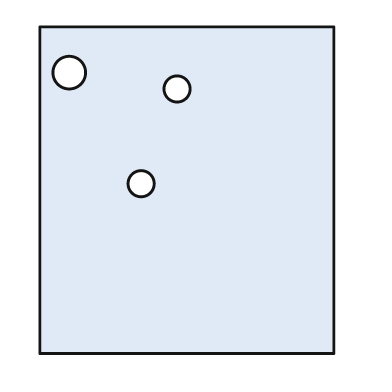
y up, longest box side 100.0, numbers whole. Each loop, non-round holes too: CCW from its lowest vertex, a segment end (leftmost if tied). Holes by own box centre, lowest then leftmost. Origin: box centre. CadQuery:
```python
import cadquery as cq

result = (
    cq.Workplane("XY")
    .moveTo(-45.0, -50.0)
    .lineTo(45.0, -50.0)
    .lineTo(45.0, 50.0)
    .lineTo(-45.0, 50.0)
    .close()
    .moveTo(-14.0, 2.0)
    .circle(4.0)
    .moveTo(-3.0, 31.0)
    .circle(4.0)
    .moveTo(-36.0, 36.0)
    .circle(5.0)
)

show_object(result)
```